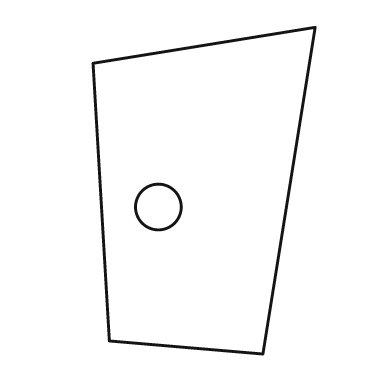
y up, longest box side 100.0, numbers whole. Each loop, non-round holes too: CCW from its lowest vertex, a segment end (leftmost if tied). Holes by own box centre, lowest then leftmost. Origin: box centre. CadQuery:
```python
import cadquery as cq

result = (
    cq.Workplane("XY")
    .moveTo(18.0, -50.0)
    .lineTo(34.0, 50.0)
    .lineTo(-34.0, 39.0)
    .lineTo(-29.0, -46.0)
    .close()
    .moveTo(-14.0, -5.0)
    .circle(7.0)
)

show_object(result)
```